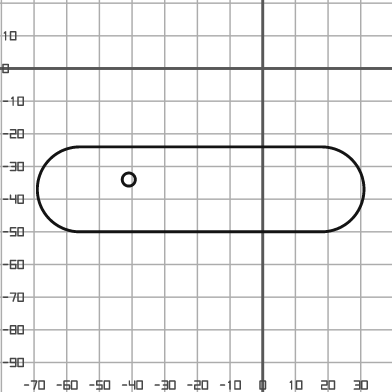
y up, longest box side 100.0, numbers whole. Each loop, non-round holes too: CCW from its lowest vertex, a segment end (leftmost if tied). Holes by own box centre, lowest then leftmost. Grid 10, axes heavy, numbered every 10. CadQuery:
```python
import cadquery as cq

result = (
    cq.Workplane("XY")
    .moveTo(-56.0, -50.0)
    .lineTo(18.0, -50.0)
    .threePointArc((31.0, -37.0), (18.0, -24.0))
    .lineTo(-56.0, -24.0)
    .threePointArc((-69.0, -37.0), (-56.0, -50.0))
    .close()
    .moveTo(-41.0, -34.0)
    .circle(2.0)
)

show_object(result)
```